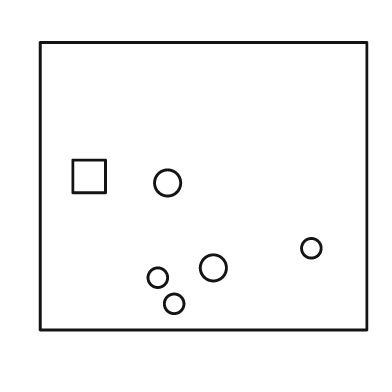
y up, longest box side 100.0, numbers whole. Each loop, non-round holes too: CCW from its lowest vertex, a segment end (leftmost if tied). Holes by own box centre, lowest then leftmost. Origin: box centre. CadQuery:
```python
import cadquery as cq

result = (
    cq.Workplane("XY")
    .moveTo(-50.0, -44.0)
    .lineTo(50.0, -44.0)
    .lineTo(50.0, 44.0)
    .lineTo(-50.0, 44.0)
    .close()
    .moveTo(-9.0, -36.0)
    .circle(3.0)
    .moveTo(-14.0, -28.0)
    .circle(3.0)
    .moveTo(3.0, -25.0)
    .circle(4.0)
    .moveTo(33.0, -19.0)
    .circle(3.0)
    .moveTo(-11.0, 1.0)
    .circle(4.0)
    .moveTo(-40.0, -2.0)
    .lineTo(-30.0, -2.0)
    .lineTo(-30.0, 8.0)
    .lineTo(-40.0, 8.0)
    .close()
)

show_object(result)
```